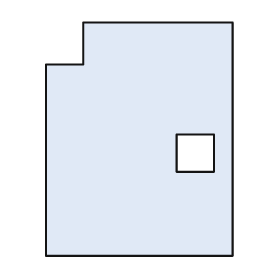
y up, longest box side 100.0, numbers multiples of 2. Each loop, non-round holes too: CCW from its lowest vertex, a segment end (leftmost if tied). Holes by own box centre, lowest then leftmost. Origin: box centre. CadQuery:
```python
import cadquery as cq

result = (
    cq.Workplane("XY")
    .moveTo(-40.0, -50.0)
    .lineTo(40.0, -50.0)
    .lineTo(40.0, 50.0)
    .lineTo(-24.0, 50.0)
    .lineTo(-24.0, 32.0)
    .lineTo(-40.0, 32.0)
    .close()
    .moveTo(16.0, -14.0)
    .lineTo(32.0, -14.0)
    .lineTo(32.0, 2.0)
    .lineTo(16.0, 2.0)
    .close()
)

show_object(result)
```